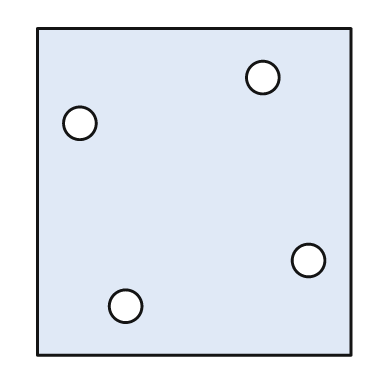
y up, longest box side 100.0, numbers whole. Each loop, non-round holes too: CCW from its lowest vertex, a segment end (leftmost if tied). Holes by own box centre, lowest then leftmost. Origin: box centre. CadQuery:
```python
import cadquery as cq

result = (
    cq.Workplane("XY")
    .moveTo(-48.0, -50.0)
    .lineTo(48.0, -50.0)
    .lineTo(48.0, 50.0)
    .lineTo(-48.0, 50.0)
    .close()
    .moveTo(-21.0, -35.0)
    .circle(5.0)
    .moveTo(35.0, -21.0)
    .circle(5.0)
    .moveTo(-35.0, 21.0)
    .circle(5.0)
    .moveTo(21.0, 35.0)
    .circle(5.0)
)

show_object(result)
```